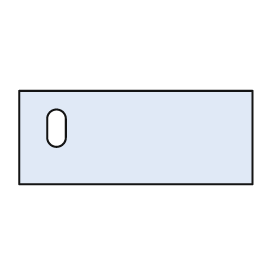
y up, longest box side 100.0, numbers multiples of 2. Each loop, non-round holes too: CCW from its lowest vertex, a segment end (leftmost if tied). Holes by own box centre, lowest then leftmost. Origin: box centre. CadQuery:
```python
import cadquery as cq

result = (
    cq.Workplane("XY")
    .moveTo(-50.0, -20.0)
    .lineTo(50.0, -20.0)
    .lineTo(50.0, 20.0)
    .lineTo(-50.0, 20.0)
    .close()
    .moveTo(-38.0, 0.0)
    .threePointArc((-34.0, -4.0), (-30.0, 0.0))
    .lineTo(-30.0, 8.0)
    .threePointArc((-34.0, 12.0), (-38.0, 8.0))
    .close()
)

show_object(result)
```